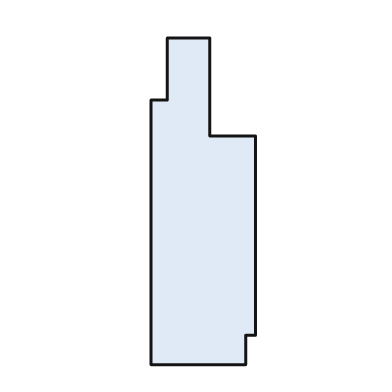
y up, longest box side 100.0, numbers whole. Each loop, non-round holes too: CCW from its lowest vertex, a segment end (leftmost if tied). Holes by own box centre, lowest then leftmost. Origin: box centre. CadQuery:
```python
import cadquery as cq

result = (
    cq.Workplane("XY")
    .moveTo(-16.0, -50.0)
    .lineTo(13.0, -50.0)
    .lineTo(13.0, -41.0)
    .lineTo(16.0, -41.0)
    .lineTo(16.0, 20.0)
    .lineTo(2.0, 20.0)
    .lineTo(2.0, 50.0)
    .lineTo(-11.0, 50.0)
    .lineTo(-11.0, 31.0)
    .lineTo(-16.0, 31.0)
    .close()
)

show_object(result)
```